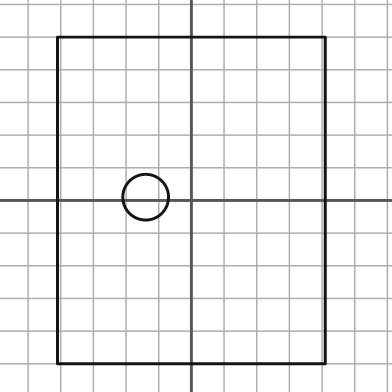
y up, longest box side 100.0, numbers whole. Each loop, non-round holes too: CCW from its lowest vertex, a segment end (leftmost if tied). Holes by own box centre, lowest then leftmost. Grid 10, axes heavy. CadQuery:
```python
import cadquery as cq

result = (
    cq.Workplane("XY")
    .moveTo(-41.0, -50.0)
    .lineTo(41.0, -50.0)
    .lineTo(41.0, 50.0)
    .lineTo(-41.0, 50.0)
    .close()
    .moveTo(-14.0, 1.0)
    .circle(7.0)
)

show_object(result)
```